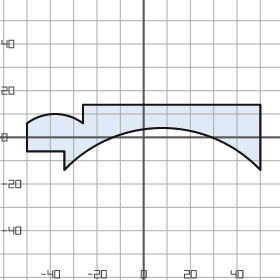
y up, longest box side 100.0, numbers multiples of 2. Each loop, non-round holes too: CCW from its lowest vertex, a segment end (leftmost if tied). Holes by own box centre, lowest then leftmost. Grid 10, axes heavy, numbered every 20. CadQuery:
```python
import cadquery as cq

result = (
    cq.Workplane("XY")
    .moveTo(-34.0, -14.0)
    .threePointArc((8.0, 4.0), (50.0, -14.0))
    .lineTo(50.0, 14.0)
    .lineTo(-26.0, 14.0)
    .lineTo(-26.0, 6.0)
    .threePointArc((-38.0, 10.0), (-50.0, 6.0))
    .lineTo(-50.0, -6.0)
    .lineTo(-34.0, -6.0)
    .close()
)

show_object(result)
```